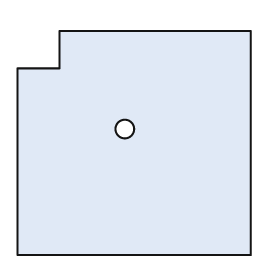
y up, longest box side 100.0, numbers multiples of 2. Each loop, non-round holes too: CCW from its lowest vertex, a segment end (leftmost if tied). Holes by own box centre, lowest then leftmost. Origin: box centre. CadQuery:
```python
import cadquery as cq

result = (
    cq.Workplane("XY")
    .moveTo(-50.0, -48.0)
    .lineTo(50.0, -48.0)
    .lineTo(50.0, 48.0)
    .lineTo(-32.0, 48.0)
    .lineTo(-32.0, 32.0)
    .lineTo(-50.0, 32.0)
    .close()
    .moveTo(-4.0, 6.0)
    .circle(4.0)
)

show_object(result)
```